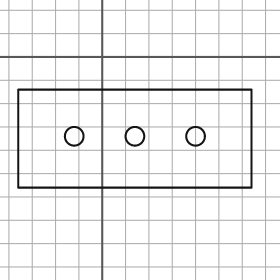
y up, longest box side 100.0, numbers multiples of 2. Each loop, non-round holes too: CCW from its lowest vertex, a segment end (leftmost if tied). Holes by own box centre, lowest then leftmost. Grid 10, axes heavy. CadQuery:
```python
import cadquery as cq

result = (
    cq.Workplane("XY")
    .moveTo(-36.0, -56.0)
    .lineTo(64.0, -56.0)
    .lineTo(64.0, -14.0)
    .lineTo(-36.0, -14.0)
    .close()
    .moveTo(-12.0, -34.0)
    .circle(4.0)
    .moveTo(14.0, -34.0)
    .circle(4.0)
    .moveTo(40.0, -34.0)
    .circle(4.0)
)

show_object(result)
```